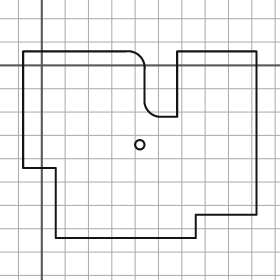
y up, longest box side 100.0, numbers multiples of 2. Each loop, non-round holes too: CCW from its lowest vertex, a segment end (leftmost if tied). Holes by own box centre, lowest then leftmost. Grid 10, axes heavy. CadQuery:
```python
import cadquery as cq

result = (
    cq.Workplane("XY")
    .moveTo(6.0, -74.0)
    .lineTo(66.0, -74.0)
    .lineTo(66.0, -64.0)
    .lineTo(92.0, -64.0)
    .lineTo(92.0, 6.0)
    .lineTo(58.0, 6.0)
    .lineTo(58.0, -22.0)
    .lineTo(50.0, -22.0)
    .threePointArc((46.0, -20.0), (44.0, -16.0))
    .lineTo(44.0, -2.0)
    .threePointArc((42.0, 4.0), (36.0, 6.0))
    .lineTo(-8.0, 6.0)
    .lineTo(-8.0, -44.0)
    .lineTo(6.0, -44.0)
    .close()
    .moveTo(42.0, -34.0)
    .circle(2.0)
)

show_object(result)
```